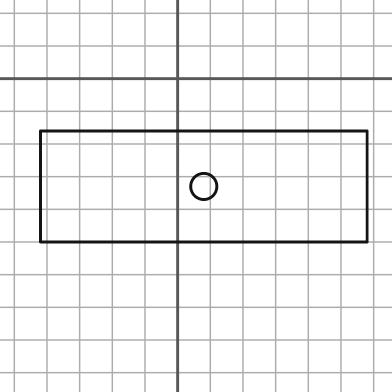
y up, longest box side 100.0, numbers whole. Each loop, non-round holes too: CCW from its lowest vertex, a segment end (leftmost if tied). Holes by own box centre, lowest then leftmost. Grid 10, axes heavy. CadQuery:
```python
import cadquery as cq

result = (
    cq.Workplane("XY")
    .moveTo(-42.0, -50.0)
    .lineTo(58.0, -50.0)
    .lineTo(58.0, -16.0)
    .lineTo(-42.0, -16.0)
    .close()
    .moveTo(8.0, -33.0)
    .circle(4.0)
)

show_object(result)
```